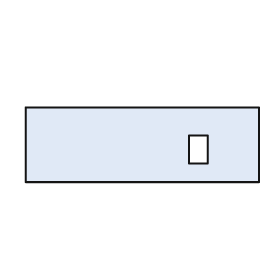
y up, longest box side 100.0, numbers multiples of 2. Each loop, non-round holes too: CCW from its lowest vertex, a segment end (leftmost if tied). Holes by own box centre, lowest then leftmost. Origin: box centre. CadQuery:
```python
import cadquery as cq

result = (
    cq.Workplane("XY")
    .moveTo(-50.0, -16.0)
    .lineTo(50.0, -16.0)
    .lineTo(50.0, 16.0)
    .lineTo(-50.0, 16.0)
    .close()
    .moveTo(20.0, -8.0)
    .lineTo(28.0, -8.0)
    .lineTo(28.0, 4.0)
    .lineTo(20.0, 4.0)
    .close()
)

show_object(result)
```